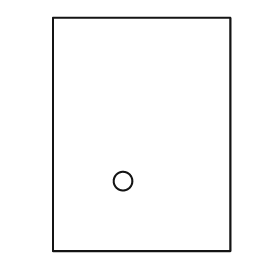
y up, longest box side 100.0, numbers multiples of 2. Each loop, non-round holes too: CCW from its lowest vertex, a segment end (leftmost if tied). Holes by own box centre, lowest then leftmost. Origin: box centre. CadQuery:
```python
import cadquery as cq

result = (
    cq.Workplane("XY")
    .moveTo(-38.0, -50.0)
    .lineTo(38.0, -50.0)
    .lineTo(38.0, 50.0)
    .lineTo(-38.0, 50.0)
    .close()
    .moveTo(-8.0, -20.0)
    .circle(4.0)
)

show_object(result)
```